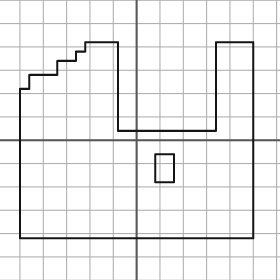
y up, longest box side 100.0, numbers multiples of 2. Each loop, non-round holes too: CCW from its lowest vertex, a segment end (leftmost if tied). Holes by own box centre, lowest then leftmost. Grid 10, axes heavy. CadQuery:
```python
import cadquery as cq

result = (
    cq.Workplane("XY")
    .moveTo(-50.0, -42.0)
    .lineTo(50.0, -42.0)
    .lineTo(50.0, 42.0)
    .lineTo(34.0, 42.0)
    .lineTo(34.0, 4.0)
    .lineTo(-8.0, 4.0)
    .lineTo(-8.0, 42.0)
    .lineTo(-22.0, 42.0)
    .lineTo(-22.0, 38.0)
    .lineTo(-26.0, 38.0)
    .lineTo(-26.0, 34.0)
    .lineTo(-34.0, 34.0)
    .lineTo(-34.0, 28.0)
    .lineTo(-46.0, 28.0)
    .lineTo(-46.0, 22.0)
    .lineTo(-50.0, 22.0)
    .close()
    .moveTo(8.0, -18.0)
    .lineTo(16.0, -18.0)
    .lineTo(16.0, -6.0)
    .lineTo(8.0, -6.0)
    .close()
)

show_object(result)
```